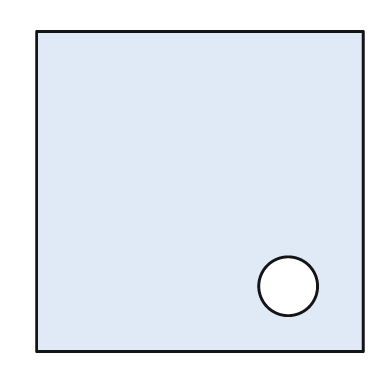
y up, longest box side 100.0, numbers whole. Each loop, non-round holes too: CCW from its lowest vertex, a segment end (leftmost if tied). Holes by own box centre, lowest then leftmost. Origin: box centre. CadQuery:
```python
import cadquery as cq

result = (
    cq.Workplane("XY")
    .moveTo(-50.0, -49.0)
    .lineTo(50.0, -49.0)
    .lineTo(50.0, 49.0)
    .lineTo(-50.0, 49.0)
    .close()
    .moveTo(27.0, -29.0)
    .circle(9.0)
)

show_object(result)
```